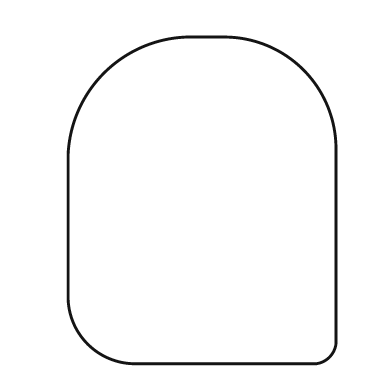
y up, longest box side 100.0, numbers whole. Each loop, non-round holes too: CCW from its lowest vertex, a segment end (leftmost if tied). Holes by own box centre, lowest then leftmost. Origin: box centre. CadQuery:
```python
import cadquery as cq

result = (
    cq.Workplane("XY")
    .moveTo(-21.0, -50.0)
    .lineTo(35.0, -50.0)
    .threePointArc((39.0, -48.0), (41.0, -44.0))
    .lineTo(41.0, 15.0)
    .threePointArc((31.0, 40.0), (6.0, 50.0))
    .lineTo(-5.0, 50.0)
    .threePointArc((-30.0, 39.0), (-41.0, 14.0))
    .lineTo(-41.0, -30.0)
    .threePointArc((-35.0, -44.0), (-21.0, -50.0))
    .close()
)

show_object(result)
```